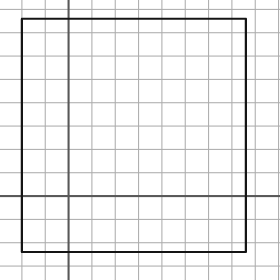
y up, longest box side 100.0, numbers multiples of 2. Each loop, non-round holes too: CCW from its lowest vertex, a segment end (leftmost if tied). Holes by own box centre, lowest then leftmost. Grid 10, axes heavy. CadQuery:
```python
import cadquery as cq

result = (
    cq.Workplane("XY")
    .moveTo(-20.0, -24.0)
    .lineTo(76.0, -24.0)
    .lineTo(76.0, 76.0)
    .lineTo(-20.0, 76.0)
    .close()
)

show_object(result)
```